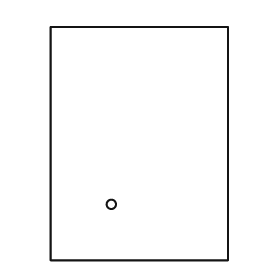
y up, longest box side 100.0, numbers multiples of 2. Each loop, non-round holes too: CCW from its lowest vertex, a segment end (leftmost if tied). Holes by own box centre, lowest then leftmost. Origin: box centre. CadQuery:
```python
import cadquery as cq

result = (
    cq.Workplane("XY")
    .moveTo(-38.0, -50.0)
    .lineTo(38.0, -50.0)
    .lineTo(38.0, 50.0)
    .lineTo(-38.0, 50.0)
    .close()
    .moveTo(-12.0, -26.0)
    .circle(2.0)
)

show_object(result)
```